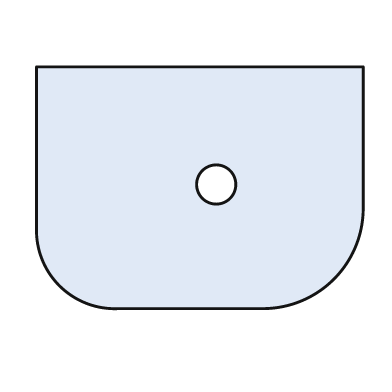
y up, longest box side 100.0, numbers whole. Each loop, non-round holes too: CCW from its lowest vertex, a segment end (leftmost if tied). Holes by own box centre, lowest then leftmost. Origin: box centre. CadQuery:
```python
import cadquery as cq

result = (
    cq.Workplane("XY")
    .moveTo(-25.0, -37.0)
    .lineTo(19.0, -37.0)
    .threePointArc((41.0, -28.0), (50.0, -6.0))
    .lineTo(50.0, 37.0)
    .lineTo(-50.0, 37.0)
    .lineTo(-50.0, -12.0)
    .threePointArc((-43.0, -30.0), (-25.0, -37.0))
    .close()
    .moveTo(5.0, 1.0)
    .circle(6.0)
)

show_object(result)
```